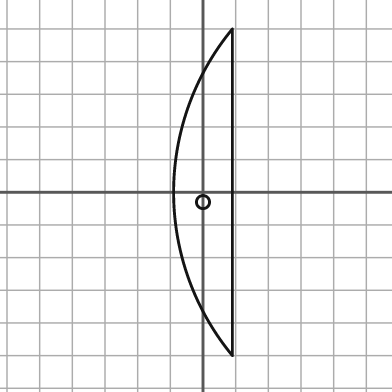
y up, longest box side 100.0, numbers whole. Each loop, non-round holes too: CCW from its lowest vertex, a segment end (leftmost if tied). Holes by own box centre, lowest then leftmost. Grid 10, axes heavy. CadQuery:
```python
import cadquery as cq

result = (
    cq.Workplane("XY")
    .moveTo(9.0, -50.0)
    .lineTo(9.0, 50.0)
    .threePointArc((-9.0, 0.0), (9.0, -50.0))
    .close()
    .moveTo(0.0, -3.0)
    .circle(2.0)
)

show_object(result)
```